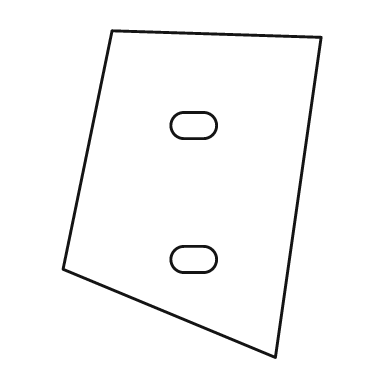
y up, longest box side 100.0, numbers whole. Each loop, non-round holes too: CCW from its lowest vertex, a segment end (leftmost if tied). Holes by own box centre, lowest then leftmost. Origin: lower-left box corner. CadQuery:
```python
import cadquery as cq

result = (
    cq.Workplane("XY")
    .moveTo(65.0, 0.0)
    .lineTo(79.0, 98.0)
    .lineTo(15.0, 100.0)
    .lineTo(0.0, 27.0)
    .close()
    .moveTo(37.0, 26.0)
    .lineTo(43.0, 26.0)
    .threePointArc((47.0, 30.0), (43.0, 34.0))
    .lineTo(37.0, 34.0)
    .threePointArc((33.0, 30.0), (37.0, 26.0))
    .close()
    .moveTo(37.0, 67.0)
    .lineTo(43.0, 67.0)
    .threePointArc((47.0, 71.0), (43.0, 75.0))
    .lineTo(37.0, 75.0)
    .threePointArc((33.0, 71.0), (37.0, 67.0))
    .close()
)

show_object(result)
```